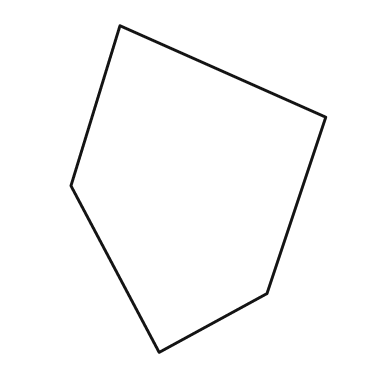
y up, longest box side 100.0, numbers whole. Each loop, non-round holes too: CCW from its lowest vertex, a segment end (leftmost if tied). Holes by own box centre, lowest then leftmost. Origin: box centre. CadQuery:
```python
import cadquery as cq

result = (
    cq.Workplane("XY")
    .moveTo(-12.0, -50.0)
    .lineTo(21.0, -32.0)
    .lineTo(39.0, 22.0)
    .lineTo(-24.0, 50.0)
    .lineTo(-39.0, 1.0)
    .close()
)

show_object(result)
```